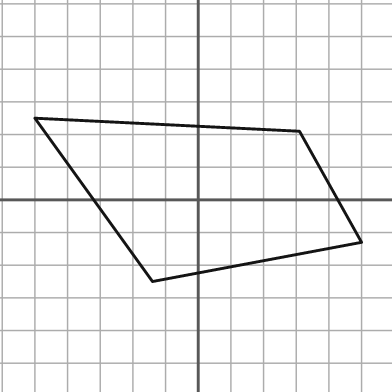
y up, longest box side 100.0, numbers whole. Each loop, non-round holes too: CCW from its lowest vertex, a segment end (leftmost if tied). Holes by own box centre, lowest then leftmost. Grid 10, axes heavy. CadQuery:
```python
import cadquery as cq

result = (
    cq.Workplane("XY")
    .moveTo(-14.0, -25.0)
    .lineTo(50.0, -13.0)
    .lineTo(31.0, 21.0)
    .lineTo(-50.0, 25.0)
    .close()
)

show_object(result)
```